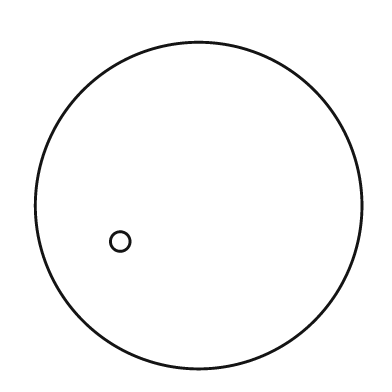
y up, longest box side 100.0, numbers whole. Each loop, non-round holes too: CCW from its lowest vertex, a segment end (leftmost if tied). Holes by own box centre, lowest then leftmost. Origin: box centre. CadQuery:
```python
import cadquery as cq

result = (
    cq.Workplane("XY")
    .moveTo(0.0, 0.0)
    .circle(50.0)
    .moveTo(-24.0, -11.0)
    .circle(3.0)
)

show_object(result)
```